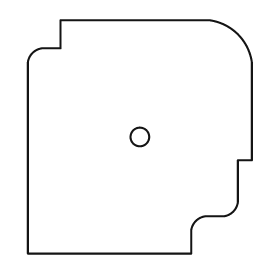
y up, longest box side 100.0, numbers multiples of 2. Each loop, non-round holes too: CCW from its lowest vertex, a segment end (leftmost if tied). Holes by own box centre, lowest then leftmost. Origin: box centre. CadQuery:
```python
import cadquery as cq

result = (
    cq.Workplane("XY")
    .moveTo(-48.0, -50.0)
    .lineTo(22.0, -50.0)
    .lineTo(22.0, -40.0)
    .threePointArc((24.0, -36.0), (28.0, -34.0))
    .lineTo(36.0, -34.0)
    .threePointArc((40.0, -32.0), (42.0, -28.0))
    .lineTo(42.0, -10.0)
    .lineTo(48.0, -10.0)
    .lineTo(48.0, 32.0)
    .threePointArc((42.0, 44.0), (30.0, 50.0))
    .lineTo(-34.0, 50.0)
    .lineTo(-34.0, 38.0)
    .lineTo(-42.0, 38.0)
    .threePointArc((-46.0, 36.0), (-48.0, 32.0))
    .close()
    .moveTo(0.0, 0.0)
    .circle(4.0)
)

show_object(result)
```